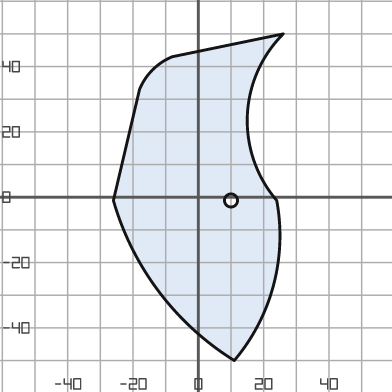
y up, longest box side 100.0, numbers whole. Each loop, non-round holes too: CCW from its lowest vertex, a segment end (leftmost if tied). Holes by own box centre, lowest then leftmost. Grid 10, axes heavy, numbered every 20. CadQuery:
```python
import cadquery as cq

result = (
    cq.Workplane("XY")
    .moveTo(11.0, -50.0)
    .threePointArc((23.0, -27.0), (24.0, -1.0))
    .threePointArc((15.0, 25.0), (26.0, 50.0))
    .lineTo(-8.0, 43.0)
    .threePointArc((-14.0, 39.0), (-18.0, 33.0))
    .lineTo(-26.0, -1.0)
    .threePointArc((-12.0, -29.0), (11.0, -50.0))
    .close()
    .moveTo(10.0, -1.0)
    .circle(2.0)
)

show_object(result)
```